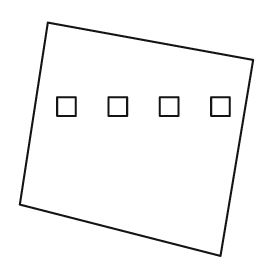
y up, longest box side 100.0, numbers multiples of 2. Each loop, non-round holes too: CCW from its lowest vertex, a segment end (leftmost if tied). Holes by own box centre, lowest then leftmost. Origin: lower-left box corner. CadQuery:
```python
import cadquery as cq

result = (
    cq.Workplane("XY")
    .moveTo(86.0, 0.0)
    .lineTo(100.0, 84.0)
    .lineTo(12.0, 100.0)
    .lineTo(0.0, 22.0)
    .close()
    .moveTo(16.0, 60.0)
    .lineTo(24.0, 60.0)
    .lineTo(24.0, 68.0)
    .lineTo(16.0, 68.0)
    .close()
    .moveTo(38.0, 60.0)
    .lineTo(46.0, 60.0)
    .lineTo(46.0, 68.0)
    .lineTo(38.0, 68.0)
    .close()
    .moveTo(60.0, 60.0)
    .lineTo(68.0, 60.0)
    .lineTo(68.0, 68.0)
    .lineTo(60.0, 68.0)
    .close()
    .moveTo(82.0, 60.0)
    .lineTo(90.0, 60.0)
    .lineTo(90.0, 68.0)
    .lineTo(82.0, 68.0)
    .close()
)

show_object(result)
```